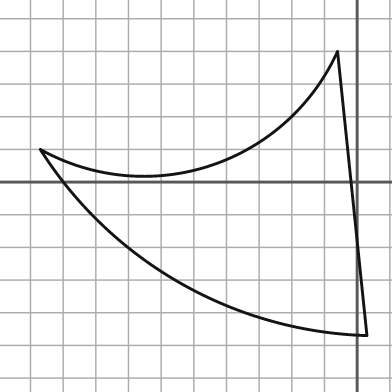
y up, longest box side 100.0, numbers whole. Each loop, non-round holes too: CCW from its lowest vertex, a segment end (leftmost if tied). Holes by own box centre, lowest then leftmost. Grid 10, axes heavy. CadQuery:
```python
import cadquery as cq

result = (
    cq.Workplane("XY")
    .moveTo(3.0, -47.0)
    .lineTo(-6.0, 40.0)
    .threePointArc((-45.0, 5.0), (-97.0, 10.0))
    .threePointArc((-54.0, -31.0), (3.0, -47.0))
    .close()
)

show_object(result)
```